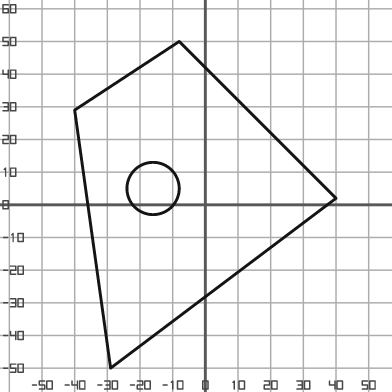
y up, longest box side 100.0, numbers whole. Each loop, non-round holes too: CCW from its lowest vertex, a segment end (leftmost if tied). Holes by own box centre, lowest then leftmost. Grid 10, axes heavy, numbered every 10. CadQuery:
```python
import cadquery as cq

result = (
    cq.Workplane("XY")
    .moveTo(-29.0, -50.0)
    .lineTo(40.0, 2.0)
    .lineTo(-8.0, 50.0)
    .lineTo(-40.0, 29.0)
    .close()
    .moveTo(-16.0, 5.0)
    .circle(8.0)
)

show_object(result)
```